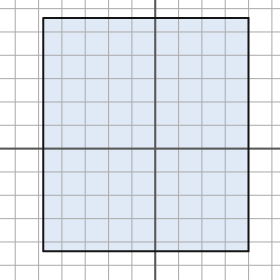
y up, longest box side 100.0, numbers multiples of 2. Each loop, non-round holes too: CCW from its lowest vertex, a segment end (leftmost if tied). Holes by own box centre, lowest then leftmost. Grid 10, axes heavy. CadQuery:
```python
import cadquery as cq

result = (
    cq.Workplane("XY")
    .moveTo(-48.0, -44.0)
    .lineTo(40.0, -44.0)
    .lineTo(40.0, 56.0)
    .lineTo(-48.0, 56.0)
    .close()
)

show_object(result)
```